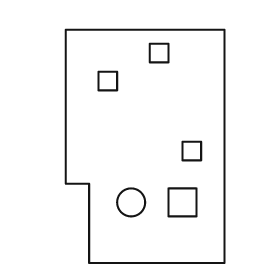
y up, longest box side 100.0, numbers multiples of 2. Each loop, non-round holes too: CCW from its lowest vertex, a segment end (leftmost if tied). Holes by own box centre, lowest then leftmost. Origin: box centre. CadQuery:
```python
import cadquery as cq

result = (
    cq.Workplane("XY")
    .moveTo(-24.0, -50.0)
    .lineTo(34.0, -50.0)
    .lineTo(34.0, 50.0)
    .lineTo(-34.0, 50.0)
    .lineTo(-34.0, -16.0)
    .lineTo(-24.0, -16.0)
    .close()
    .moveTo(-6.0, -24.0)
    .circle(6.0)
    .moveTo(10.0, -30.0)
    .lineTo(22.0, -30.0)
    .lineTo(22.0, -18.0)
    .lineTo(10.0, -18.0)
    .close()
    .moveTo(16.0, -6.0)
    .lineTo(24.0, -6.0)
    .lineTo(24.0, 2.0)
    .lineTo(16.0, 2.0)
    .close()
    .moveTo(-20.0, 24.0)
    .lineTo(-12.0, 24.0)
    .lineTo(-12.0, 32.0)
    .lineTo(-20.0, 32.0)
    .close()
    .moveTo(2.0, 36.0)
    .lineTo(10.0, 36.0)
    .lineTo(10.0, 44.0)
    .lineTo(2.0, 44.0)
    .close()
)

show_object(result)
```